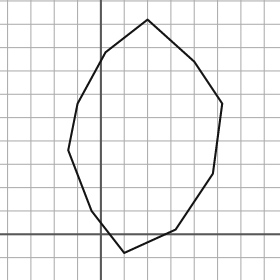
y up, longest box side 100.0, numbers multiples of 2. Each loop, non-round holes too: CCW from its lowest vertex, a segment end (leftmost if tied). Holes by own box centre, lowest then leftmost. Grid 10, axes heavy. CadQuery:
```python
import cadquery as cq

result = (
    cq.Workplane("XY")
    .moveTo(10.0, -8.0)
    .lineTo(32.0, 2.0)
    .lineTo(48.0, 26.0)
    .lineTo(52.0, 56.0)
    .lineTo(40.0, 74.0)
    .lineTo(20.0, 92.0)
    .lineTo(2.0, 78.0)
    .lineTo(-10.0, 56.0)
    .lineTo(-14.0, 36.0)
    .lineTo(-4.0, 10.0)
    .close()
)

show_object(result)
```